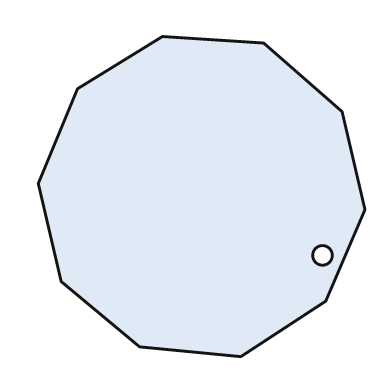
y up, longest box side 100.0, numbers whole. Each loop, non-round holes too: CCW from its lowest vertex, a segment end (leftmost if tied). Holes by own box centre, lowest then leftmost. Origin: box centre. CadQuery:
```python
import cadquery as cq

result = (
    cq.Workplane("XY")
    .moveTo(12.0, -49.0)
    .lineTo(38.0, -32.0)
    .lineTo(50.0, -4.0)
    .lineTo(43.0, 26.0)
    .lineTo(19.0, 47.0)
    .lineTo(-12.0, 49.0)
    .lineTo(-38.0, 33.0)
    .lineTo(-50.0, 4.0)
    .lineTo(-43.0, -26.0)
    .lineTo(-19.0, -46.0)
    .close()
    .moveTo(37.0, -18.0)
    .circle(3.0)
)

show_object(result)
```